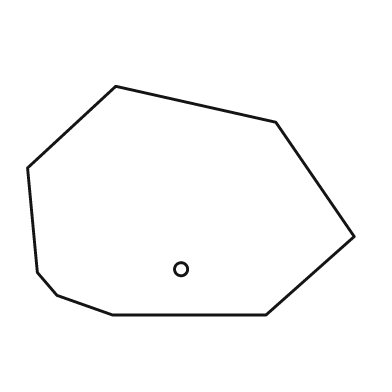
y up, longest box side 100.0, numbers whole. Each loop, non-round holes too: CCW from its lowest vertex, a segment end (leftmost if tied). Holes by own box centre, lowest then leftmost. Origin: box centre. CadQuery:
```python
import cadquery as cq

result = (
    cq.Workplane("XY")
    .moveTo(-24.0, -35.0)
    .lineTo(23.0, -35.0)
    .lineTo(50.0, -11.0)
    .lineTo(26.0, 24.0)
    .lineTo(-23.0, 35.0)
    .lineTo(-50.0, 10.0)
    .lineTo(-47.0, -22.0)
    .lineTo(-41.0, -29.0)
    .close()
    .moveTo(-3.0, -21.0)
    .circle(2.0)
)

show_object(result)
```